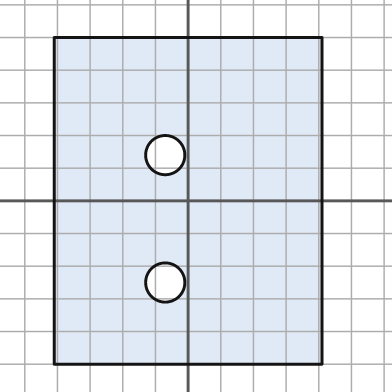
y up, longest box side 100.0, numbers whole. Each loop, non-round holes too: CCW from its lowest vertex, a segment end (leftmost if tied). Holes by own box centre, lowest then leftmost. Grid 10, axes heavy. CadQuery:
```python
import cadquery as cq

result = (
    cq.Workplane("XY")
    .moveTo(-41.0, -50.0)
    .lineTo(41.0, -50.0)
    .lineTo(41.0, 50.0)
    .lineTo(-41.0, 50.0)
    .close()
    .moveTo(-7.0, -25.0)
    .circle(6.0)
    .moveTo(-7.0, 14.0)
    .circle(6.0)
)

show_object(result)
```